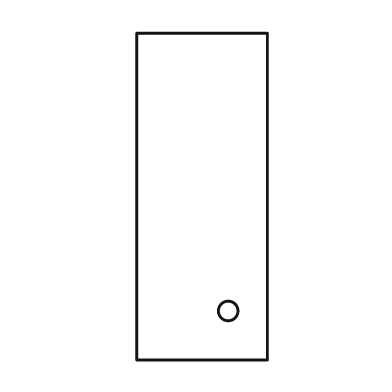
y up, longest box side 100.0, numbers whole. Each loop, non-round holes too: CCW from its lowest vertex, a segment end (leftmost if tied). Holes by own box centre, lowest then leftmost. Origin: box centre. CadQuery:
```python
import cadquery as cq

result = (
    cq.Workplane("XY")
    .moveTo(-20.0, -50.0)
    .lineTo(20.0, -50.0)
    .lineTo(20.0, 50.0)
    .lineTo(-20.0, 50.0)
    .close()
    .moveTo(8.0, -35.0)
    .circle(3.0)
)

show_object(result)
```